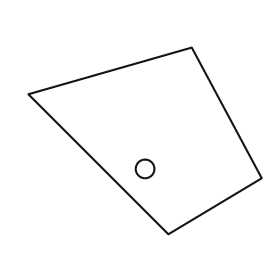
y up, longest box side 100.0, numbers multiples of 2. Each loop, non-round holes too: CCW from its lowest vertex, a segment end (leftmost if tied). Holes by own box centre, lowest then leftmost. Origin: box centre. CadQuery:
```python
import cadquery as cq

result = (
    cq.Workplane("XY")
    .moveTo(10.0, -40.0)
    .lineTo(50.0, -16.0)
    .lineTo(20.0, 40.0)
    .lineTo(-50.0, 20.0)
    .close()
    .moveTo(0.0, -12.0)
    .circle(4.0)
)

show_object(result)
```